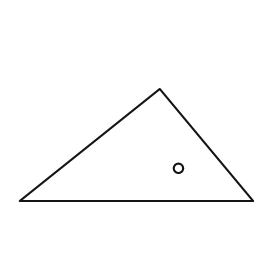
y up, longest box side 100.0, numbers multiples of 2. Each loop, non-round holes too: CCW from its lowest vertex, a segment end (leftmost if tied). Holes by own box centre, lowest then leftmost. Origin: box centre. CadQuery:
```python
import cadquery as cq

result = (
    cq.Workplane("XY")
    .moveTo(-50.0, -24.0)
    .lineTo(50.0, -24.0)
    .lineTo(10.0, 24.0)
    .close()
    .moveTo(18.0, -10.0)
    .circle(2.0)
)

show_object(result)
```